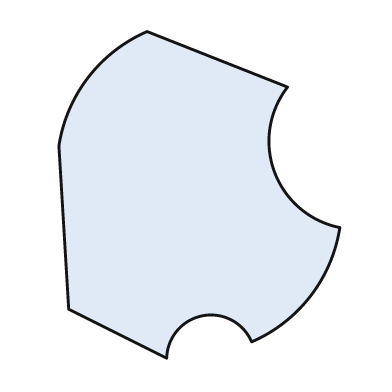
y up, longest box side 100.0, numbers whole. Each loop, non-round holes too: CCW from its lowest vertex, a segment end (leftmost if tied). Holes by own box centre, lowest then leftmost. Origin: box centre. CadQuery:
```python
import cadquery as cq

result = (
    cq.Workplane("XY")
    .moveTo(-10.0, -50.0)
    .threePointArc((1.0, -37.0), (16.0, -45.0))
    .threePointArc((34.0, -31.0), (43.0, -10.0))
    .threePointArc((23.0, 7.0), (27.0, 33.0))
    .lineTo(-16.0, 50.0)
    .threePointArc((-34.0, 36.0), (-43.0, 15.0))
    .lineTo(-40.0, -35.0)
    .close()
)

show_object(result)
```